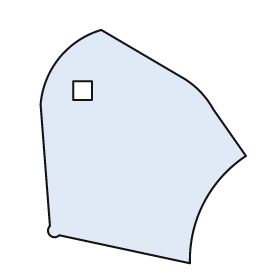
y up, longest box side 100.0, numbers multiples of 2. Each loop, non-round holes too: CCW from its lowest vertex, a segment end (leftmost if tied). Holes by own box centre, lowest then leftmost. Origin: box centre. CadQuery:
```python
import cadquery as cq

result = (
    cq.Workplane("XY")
    .moveTo(20.0, -50.0)
    .threePointArc((26.0, -24.0), (44.0, -4.0))
    .lineTo(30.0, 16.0)
    .threePointArc((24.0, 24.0), (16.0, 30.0))
    .lineTo(-18.0, 50.0)
    .threePointArc((-36.0, 38.0), (-44.0, 18.0))
    .lineTo(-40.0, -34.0)
    .threePointArc((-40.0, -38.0), (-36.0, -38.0))
    .close()
    .moveTo(-30.0, 20.0)
    .lineTo(-22.0, 20.0)
    .lineTo(-22.0, 28.0)
    .lineTo(-30.0, 28.0)
    .close()
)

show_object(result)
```